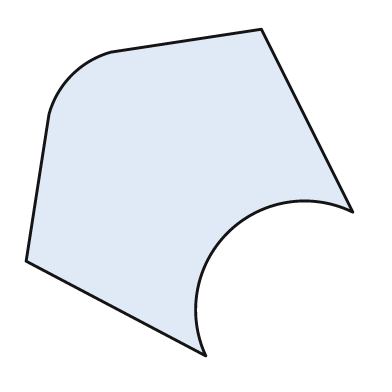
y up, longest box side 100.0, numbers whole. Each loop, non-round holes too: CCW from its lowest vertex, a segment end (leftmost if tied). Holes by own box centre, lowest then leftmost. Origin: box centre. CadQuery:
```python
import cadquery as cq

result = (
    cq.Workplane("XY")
    .moveTo(5.0, -50.0)
    .threePointArc((12.0, -12.0), (50.0, -6.0))
    .lineTo(22.0, 50.0)
    .lineTo(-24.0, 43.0)
    .threePointArc((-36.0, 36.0), (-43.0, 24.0))
    .lineTo(-50.0, -21.0)
    .close()
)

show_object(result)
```